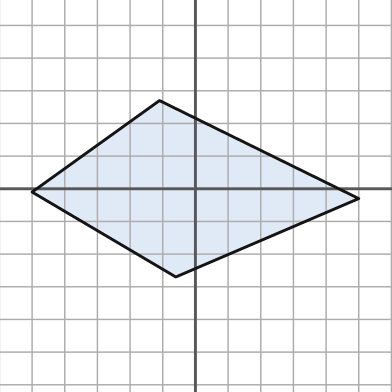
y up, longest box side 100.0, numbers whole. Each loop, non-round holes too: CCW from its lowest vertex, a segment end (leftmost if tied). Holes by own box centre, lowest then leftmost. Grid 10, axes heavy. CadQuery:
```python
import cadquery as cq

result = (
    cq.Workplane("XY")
    .moveTo(-6.0, -27.0)
    .lineTo(50.0, -3.0)
    .lineTo(-11.0, 27.0)
    .lineTo(-50.0, -1.0)
    .close()
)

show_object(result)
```